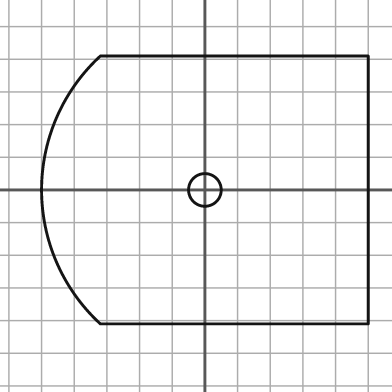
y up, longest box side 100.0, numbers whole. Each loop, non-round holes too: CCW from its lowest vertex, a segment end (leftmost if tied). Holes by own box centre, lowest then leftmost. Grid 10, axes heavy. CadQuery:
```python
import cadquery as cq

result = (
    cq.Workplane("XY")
    .moveTo(-32.0, -41.0)
    .lineTo(50.0, -41.0)
    .lineTo(50.0, 41.0)
    .lineTo(-32.0, 41.0)
    .threePointArc((-50.0, 0.0), (-32.0, -41.0))
    .close()
    .moveTo(0.0, 0.0)
    .circle(5.0)
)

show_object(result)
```